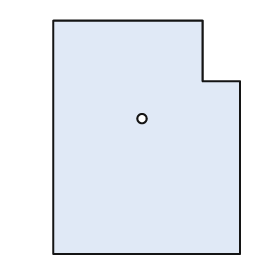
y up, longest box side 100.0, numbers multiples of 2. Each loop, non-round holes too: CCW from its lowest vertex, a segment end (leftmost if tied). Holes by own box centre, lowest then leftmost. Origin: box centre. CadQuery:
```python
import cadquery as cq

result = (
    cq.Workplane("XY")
    .moveTo(-40.0, -50.0)
    .lineTo(40.0, -50.0)
    .lineTo(40.0, 24.0)
    .lineTo(24.0, 24.0)
    .lineTo(24.0, 50.0)
    .lineTo(-40.0, 50.0)
    .close()
    .moveTo(-2.0, 8.0)
    .circle(2.0)
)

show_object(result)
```